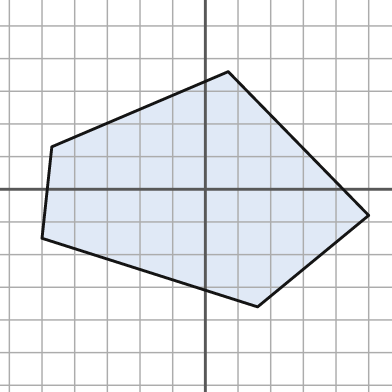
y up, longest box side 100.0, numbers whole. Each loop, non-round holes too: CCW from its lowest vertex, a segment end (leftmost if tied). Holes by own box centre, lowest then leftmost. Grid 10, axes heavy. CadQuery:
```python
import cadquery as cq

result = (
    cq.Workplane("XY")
    .moveTo(16.0, -36.0)
    .lineTo(50.0, -8.0)
    .lineTo(7.0, 36.0)
    .lineTo(-47.0, 13.0)
    .lineTo(-50.0, -15.0)
    .close()
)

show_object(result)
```